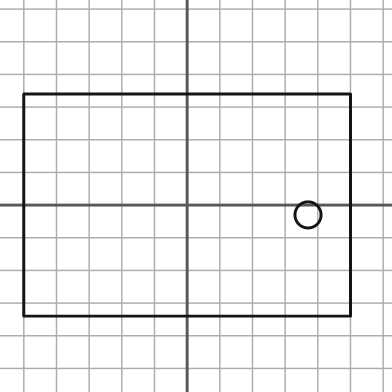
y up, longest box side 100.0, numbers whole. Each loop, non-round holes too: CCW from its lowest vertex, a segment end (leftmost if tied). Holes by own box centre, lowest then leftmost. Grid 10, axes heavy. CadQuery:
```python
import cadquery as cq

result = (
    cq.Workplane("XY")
    .moveTo(-50.0, -34.0)
    .lineTo(50.0, -34.0)
    .lineTo(50.0, 34.0)
    .lineTo(-50.0, 34.0)
    .close()
    .moveTo(37.0, -3.0)
    .circle(4.0)
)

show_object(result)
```